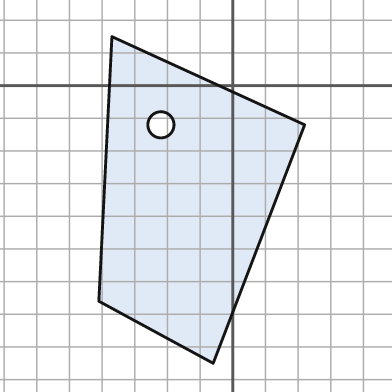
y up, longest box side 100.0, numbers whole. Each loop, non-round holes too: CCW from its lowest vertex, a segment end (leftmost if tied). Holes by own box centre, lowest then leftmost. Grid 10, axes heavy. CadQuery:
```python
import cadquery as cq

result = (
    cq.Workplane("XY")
    .moveTo(-6.0, -85.0)
    .lineTo(22.0, -12.0)
    .lineTo(-37.0, 15.0)
    .lineTo(-41.0, -66.0)
    .close()
    .moveTo(-22.0, -12.0)
    .circle(4.0)
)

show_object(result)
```